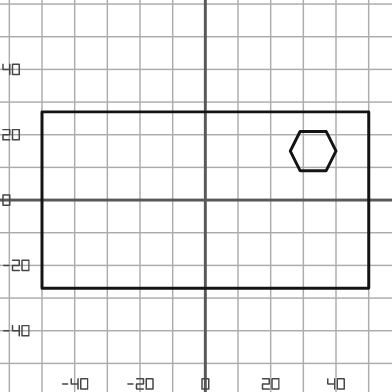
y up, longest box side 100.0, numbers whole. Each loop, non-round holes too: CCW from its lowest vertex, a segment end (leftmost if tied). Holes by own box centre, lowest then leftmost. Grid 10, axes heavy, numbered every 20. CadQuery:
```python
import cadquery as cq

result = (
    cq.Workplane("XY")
    .moveTo(-50.0, -27.0)
    .lineTo(50.0, -27.0)
    .lineTo(50.0, 27.0)
    .lineTo(-50.0, 27.0)
    .close()
    .moveTo(29.0, 9.0)
    .lineTo(37.0, 9.0)
    .lineTo(40.0, 15.0)
    .lineTo(37.0, 21.0)
    .lineTo(29.0, 21.0)
    .lineTo(26.0, 15.0)
    .close()
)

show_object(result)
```